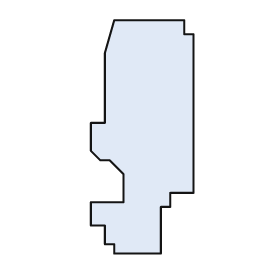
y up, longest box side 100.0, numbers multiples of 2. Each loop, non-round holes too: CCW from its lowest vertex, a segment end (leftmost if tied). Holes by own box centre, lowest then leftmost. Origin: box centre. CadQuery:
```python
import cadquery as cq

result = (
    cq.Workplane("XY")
    .moveTo(-12.0, -50.0)
    .lineTo(8.0, -50.0)
    .lineTo(8.0, -30.0)
    .lineTo(12.0, -30.0)
    .lineTo(12.0, -24.0)
    .lineTo(22.0, -24.0)
    .lineTo(22.0, 44.0)
    .lineTo(18.0, 44.0)
    .lineTo(18.0, 50.0)
    .lineTo(-12.0, 50.0)
    .lineTo(-16.0, 36.0)
    .lineTo(-16.0, 6.0)
    .lineTo(-22.0, 6.0)
    .lineTo(-22.0, -6.0)
    .lineTo(-18.0, -10.0)
    .lineTo(-14.0, -10.0)
    .lineTo(-8.0, -16.0)
    .lineTo(-8.0, -28.0)
    .lineTo(-22.0, -28.0)
    .lineTo(-22.0, -38.0)
    .lineTo(-16.0, -38.0)
    .lineTo(-16.0, -46.0)
    .lineTo(-12.0, -46.0)
    .close()
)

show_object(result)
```